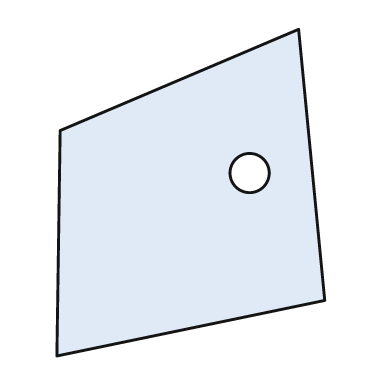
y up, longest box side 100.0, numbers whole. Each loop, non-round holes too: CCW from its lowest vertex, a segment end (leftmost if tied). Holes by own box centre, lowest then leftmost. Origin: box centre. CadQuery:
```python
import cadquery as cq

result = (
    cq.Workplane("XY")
    .moveTo(-41.0, -50.0)
    .lineTo(41.0, -33.0)
    .lineTo(33.0, 50.0)
    .lineTo(-40.0, 19.0)
    .close()
    .moveTo(18.0, 6.0)
    .circle(6.0)
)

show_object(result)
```